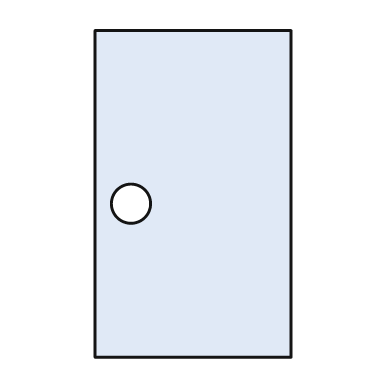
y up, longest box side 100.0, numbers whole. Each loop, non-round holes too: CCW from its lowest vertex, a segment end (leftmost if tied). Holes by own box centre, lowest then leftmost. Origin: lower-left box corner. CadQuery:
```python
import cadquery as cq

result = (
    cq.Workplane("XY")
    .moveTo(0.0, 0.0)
    .lineTo(60.0, 0.0)
    .lineTo(60.0, 100.0)
    .lineTo(0.0, 100.0)
    .close()
    .moveTo(11.0, 47.0)
    .circle(6.0)
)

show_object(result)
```